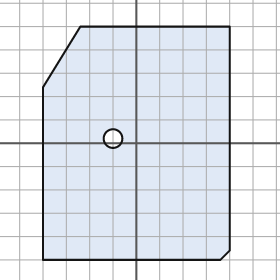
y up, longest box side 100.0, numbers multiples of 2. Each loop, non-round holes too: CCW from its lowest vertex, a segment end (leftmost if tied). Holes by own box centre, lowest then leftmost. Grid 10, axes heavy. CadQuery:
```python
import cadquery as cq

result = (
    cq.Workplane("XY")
    .moveTo(-40.0, -50.0)
    .lineTo(36.0, -50.0)
    .lineTo(40.0, -46.0)
    .lineTo(40.0, 50.0)
    .lineTo(-24.0, 50.0)
    .lineTo(-40.0, 24.0)
    .close()
    .moveTo(-10.0, 2.0)
    .circle(4.0)
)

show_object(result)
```